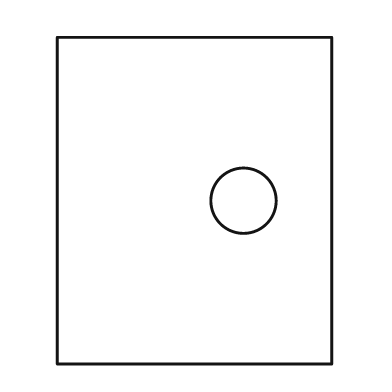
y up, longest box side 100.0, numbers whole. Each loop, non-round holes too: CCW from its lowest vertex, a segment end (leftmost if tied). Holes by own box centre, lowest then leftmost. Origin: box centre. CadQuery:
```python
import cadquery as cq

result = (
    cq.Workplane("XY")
    .moveTo(-42.0, -50.0)
    .lineTo(42.0, -50.0)
    .lineTo(42.0, 50.0)
    .lineTo(-42.0, 50.0)
    .close()
    .moveTo(15.0, 0.0)
    .circle(10.0)
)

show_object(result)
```